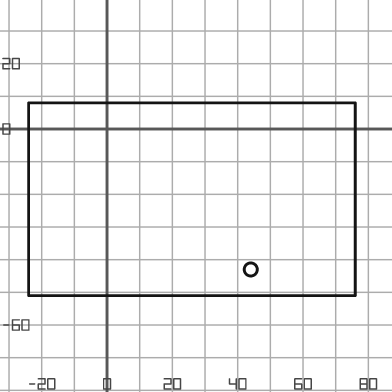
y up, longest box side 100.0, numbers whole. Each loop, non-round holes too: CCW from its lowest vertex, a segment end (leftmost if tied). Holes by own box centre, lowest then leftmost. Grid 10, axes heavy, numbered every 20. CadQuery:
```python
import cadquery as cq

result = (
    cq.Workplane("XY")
    .moveTo(-24.0, -51.0)
    .lineTo(76.0, -51.0)
    .lineTo(76.0, 8.0)
    .lineTo(-24.0, 8.0)
    .close()
    .moveTo(44.0, -43.0)
    .circle(2.0)
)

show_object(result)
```